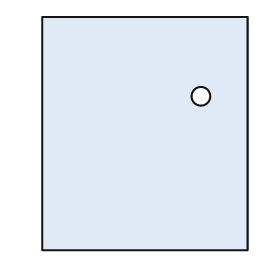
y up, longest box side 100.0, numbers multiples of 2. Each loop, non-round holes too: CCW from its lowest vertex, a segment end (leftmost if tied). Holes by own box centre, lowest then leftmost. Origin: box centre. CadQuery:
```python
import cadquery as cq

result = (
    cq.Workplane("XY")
    .moveTo(-44.0, -50.0)
    .lineTo(44.0, -50.0)
    .lineTo(44.0, 50.0)
    .lineTo(-44.0, 50.0)
    .close()
    .moveTo(24.0, 16.0)
    .circle(4.0)
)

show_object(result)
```